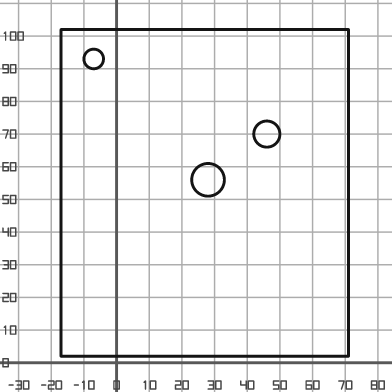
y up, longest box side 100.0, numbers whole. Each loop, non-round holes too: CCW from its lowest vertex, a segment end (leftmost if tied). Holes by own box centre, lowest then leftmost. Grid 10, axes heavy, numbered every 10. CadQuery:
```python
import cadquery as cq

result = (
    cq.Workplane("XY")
    .moveTo(-17.0, 2.0)
    .lineTo(71.0, 2.0)
    .lineTo(71.0, 102.0)
    .lineTo(-17.0, 102.0)
    .close()
    .moveTo(28.0, 56.0)
    .circle(5.0)
    .moveTo(46.0, 70.0)
    .circle(4.0)
    .moveTo(-7.0, 93.0)
    .circle(3.0)
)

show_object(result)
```